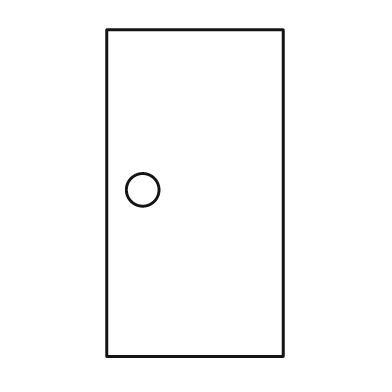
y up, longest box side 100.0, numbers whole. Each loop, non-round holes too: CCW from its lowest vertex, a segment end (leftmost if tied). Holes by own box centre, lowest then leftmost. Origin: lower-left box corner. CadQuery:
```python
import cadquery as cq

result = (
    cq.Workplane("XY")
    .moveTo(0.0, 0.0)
    .lineTo(54.0, 0.0)
    .lineTo(54.0, 100.0)
    .lineTo(0.0, 100.0)
    .close()
    .moveTo(11.0, 51.0)
    .circle(5.0)
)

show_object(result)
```